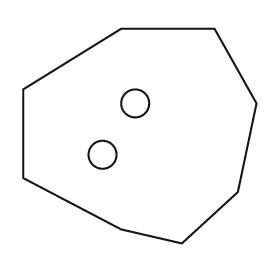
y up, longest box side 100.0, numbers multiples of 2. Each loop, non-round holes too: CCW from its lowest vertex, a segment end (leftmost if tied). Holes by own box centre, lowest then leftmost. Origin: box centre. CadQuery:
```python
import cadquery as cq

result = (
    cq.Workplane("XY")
    .moveTo(18.0, -46.0)
    .lineTo(42.0, -24.0)
    .lineTo(50.0, 14.0)
    .lineTo(32.0, 46.0)
    .lineTo(-8.0, 46.0)
    .lineTo(-50.0, 20.0)
    .lineTo(-50.0, -18.0)
    .lineTo(-8.0, -40.0)
    .close()
    .moveTo(-16.0, -8.0)
    .circle(6.0)
    .moveTo(-2.0, 14.0)
    .circle(6.0)
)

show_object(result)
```